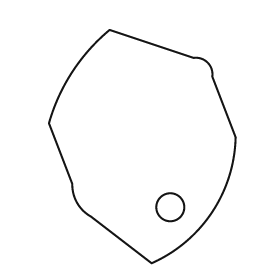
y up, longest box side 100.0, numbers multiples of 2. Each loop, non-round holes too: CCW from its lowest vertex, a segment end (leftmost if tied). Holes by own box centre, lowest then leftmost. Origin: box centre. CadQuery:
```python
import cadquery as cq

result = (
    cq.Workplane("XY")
    .moveTo(4.0, -50.0)
    .threePointArc((30.0, -28.0), (40.0, 4.0))
    .lineTo(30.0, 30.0)
    .threePointArc((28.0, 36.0), (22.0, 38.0))
    .lineTo(-14.0, 50.0)
    .threePointArc((-30.0, 32.0), (-40.0, 10.0))
    .lineTo(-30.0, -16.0)
    .threePointArc((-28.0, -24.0), (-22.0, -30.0))
    .close()
    .moveTo(12.0, -26.0)
    .circle(6.0)
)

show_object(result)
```